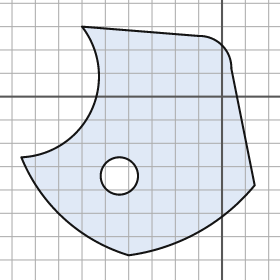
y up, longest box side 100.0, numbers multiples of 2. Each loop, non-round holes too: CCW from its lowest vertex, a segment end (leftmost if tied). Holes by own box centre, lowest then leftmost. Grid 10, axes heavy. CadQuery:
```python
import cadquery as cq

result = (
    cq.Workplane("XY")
    .moveTo(-40.0, -68.0)
    .threePointArc((-10.0, -58.0), (14.0, -38.0))
    .lineTo(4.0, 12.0)
    .threePointArc((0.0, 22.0), (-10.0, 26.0))
    .lineTo(-60.0, 30.0)
    .threePointArc((-56.0, -6.0), (-86.0, -26.0))
    .threePointArc((-68.0, -52.0), (-40.0, -68.0))
    .close()
    .moveTo(-44.0, -34.0)
    .circle(8.0)
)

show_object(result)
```